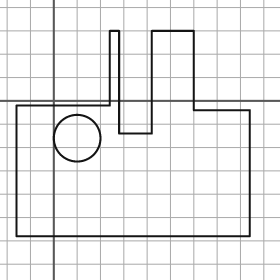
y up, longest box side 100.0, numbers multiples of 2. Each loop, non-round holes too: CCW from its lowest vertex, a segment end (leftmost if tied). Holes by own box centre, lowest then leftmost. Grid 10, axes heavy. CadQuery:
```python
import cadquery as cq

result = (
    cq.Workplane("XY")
    .moveTo(-16.0, -58.0)
    .lineTo(84.0, -58.0)
    .lineTo(84.0, -4.0)
    .lineTo(60.0, -4.0)
    .lineTo(60.0, 30.0)
    .lineTo(42.0, 30.0)
    .lineTo(42.0, -14.0)
    .lineTo(28.0, -14.0)
    .lineTo(28.0, 30.0)
    .lineTo(24.0, 30.0)
    .lineTo(24.0, -2.0)
    .lineTo(-16.0, -2.0)
    .close()
    .moveTo(10.0, -16.0)
    .circle(10.0)
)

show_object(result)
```